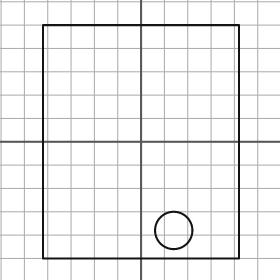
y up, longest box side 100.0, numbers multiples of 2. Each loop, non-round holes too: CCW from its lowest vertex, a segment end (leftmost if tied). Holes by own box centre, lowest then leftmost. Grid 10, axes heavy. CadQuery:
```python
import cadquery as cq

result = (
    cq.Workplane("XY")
    .moveTo(-42.0, -50.0)
    .lineTo(42.0, -50.0)
    .lineTo(42.0, 50.0)
    .lineTo(-42.0, 50.0)
    .close()
    .moveTo(14.0, -38.0)
    .circle(8.0)
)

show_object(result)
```